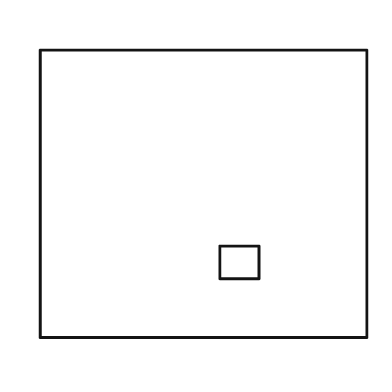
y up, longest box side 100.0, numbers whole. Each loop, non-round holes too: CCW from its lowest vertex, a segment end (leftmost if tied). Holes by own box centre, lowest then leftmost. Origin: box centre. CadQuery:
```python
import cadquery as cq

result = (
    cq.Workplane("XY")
    .moveTo(-50.0, -44.0)
    .lineTo(50.0, -44.0)
    .lineTo(50.0, 44.0)
    .lineTo(-50.0, 44.0)
    .close()
    .moveTo(5.0, -26.0)
    .lineTo(17.0, -26.0)
    .lineTo(17.0, -16.0)
    .lineTo(5.0, -16.0)
    .close()
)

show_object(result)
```